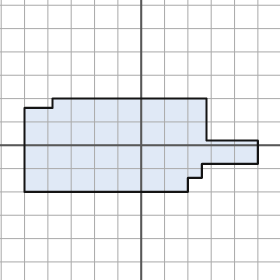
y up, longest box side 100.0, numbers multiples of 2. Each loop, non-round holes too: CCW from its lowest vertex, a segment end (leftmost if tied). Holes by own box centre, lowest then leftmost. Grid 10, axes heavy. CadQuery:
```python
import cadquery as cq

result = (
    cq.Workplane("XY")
    .moveTo(-50.0, -20.0)
    .lineTo(20.0, -20.0)
    .lineTo(20.0, -14.0)
    .lineTo(26.0, -14.0)
    .lineTo(26.0, -8.0)
    .lineTo(50.0, -8.0)
    .lineTo(50.0, 2.0)
    .lineTo(28.0, 2.0)
    .lineTo(28.0, 20.0)
    .lineTo(-38.0, 20.0)
    .lineTo(-38.0, 16.0)
    .lineTo(-50.0, 16.0)
    .close()
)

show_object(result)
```